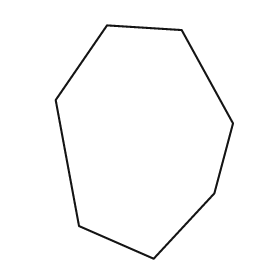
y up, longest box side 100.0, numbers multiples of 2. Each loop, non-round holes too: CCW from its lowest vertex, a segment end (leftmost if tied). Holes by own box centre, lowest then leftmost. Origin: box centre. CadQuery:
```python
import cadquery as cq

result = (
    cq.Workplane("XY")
    .moveTo(4.0, -50.0)
    .lineTo(30.0, -22.0)
    .lineTo(38.0, 8.0)
    .lineTo(16.0, 48.0)
    .lineTo(-16.0, 50.0)
    .lineTo(-38.0, 18.0)
    .lineTo(-28.0, -36.0)
    .close()
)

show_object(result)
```